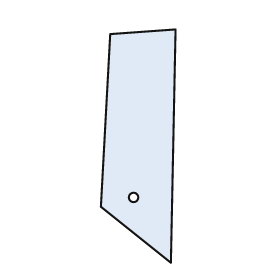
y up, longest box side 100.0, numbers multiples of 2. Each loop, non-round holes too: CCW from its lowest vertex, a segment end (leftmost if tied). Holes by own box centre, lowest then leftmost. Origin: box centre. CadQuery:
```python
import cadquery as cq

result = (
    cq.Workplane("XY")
    .moveTo(14.0, -50.0)
    .lineTo(16.0, 50.0)
    .lineTo(-12.0, 48.0)
    .lineTo(-16.0, -26.0)
    .close()
    .moveTo(-2.0, -22.0)
    .circle(2.0)
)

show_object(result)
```